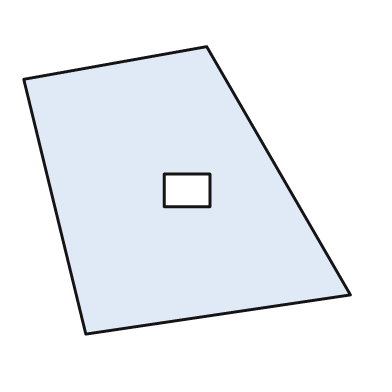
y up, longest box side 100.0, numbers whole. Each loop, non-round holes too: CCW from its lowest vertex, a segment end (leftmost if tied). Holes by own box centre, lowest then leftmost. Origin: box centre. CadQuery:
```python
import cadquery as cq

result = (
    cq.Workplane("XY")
    .moveTo(-31.0, -44.0)
    .lineTo(50.0, -32.0)
    .lineTo(6.0, 44.0)
    .lineTo(-50.0, 34.0)
    .close()
    .moveTo(-7.0, -5.0)
    .lineTo(7.0, -5.0)
    .lineTo(7.0, 5.0)
    .lineTo(-7.0, 5.0)
    .close()
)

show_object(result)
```